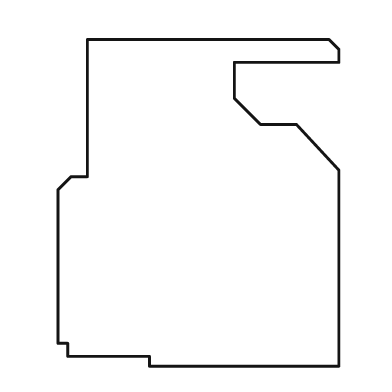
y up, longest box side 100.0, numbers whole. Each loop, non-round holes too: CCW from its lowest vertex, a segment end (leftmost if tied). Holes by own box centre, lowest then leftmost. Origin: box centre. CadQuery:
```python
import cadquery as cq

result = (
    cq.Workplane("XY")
    .moveTo(-15.0, -50.0)
    .lineTo(43.0, -50.0)
    .lineTo(43.0, 10.0)
    .lineTo(30.0, 24.0)
    .lineTo(19.0, 24.0)
    .lineTo(11.0, 32.0)
    .lineTo(11.0, 43.0)
    .lineTo(43.0, 43.0)
    .lineTo(43.0, 47.0)
    .lineTo(40.0, 50.0)
    .lineTo(-34.0, 50.0)
    .lineTo(-34.0, 8.0)
    .lineTo(-39.0, 8.0)
    .lineTo(-43.0, 4.0)
    .lineTo(-43.0, -43.0)
    .lineTo(-40.0, -43.0)
    .lineTo(-40.0, -47.0)
    .lineTo(-15.0, -47.0)
    .close()
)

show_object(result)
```